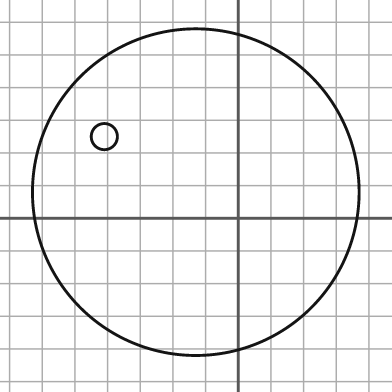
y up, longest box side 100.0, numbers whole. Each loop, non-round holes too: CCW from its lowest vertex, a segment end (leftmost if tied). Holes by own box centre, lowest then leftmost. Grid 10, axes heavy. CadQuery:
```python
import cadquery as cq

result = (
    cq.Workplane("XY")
    .moveTo(-13.0, 8.0)
    .circle(50.0)
    .moveTo(-41.0, 25.0)
    .circle(4.0)
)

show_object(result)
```